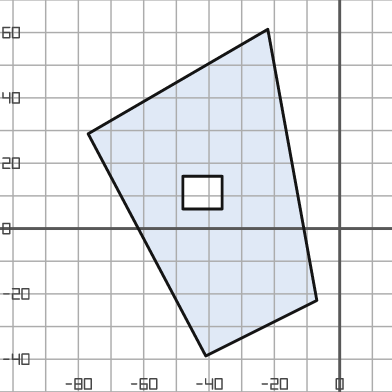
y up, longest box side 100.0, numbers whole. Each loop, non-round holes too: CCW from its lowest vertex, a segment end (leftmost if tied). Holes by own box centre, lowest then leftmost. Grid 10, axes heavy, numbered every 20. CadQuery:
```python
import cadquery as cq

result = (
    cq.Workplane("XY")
    .moveTo(-41.0, -39.0)
    .lineTo(-7.0, -22.0)
    .lineTo(-22.0, 61.0)
    .lineTo(-77.0, 29.0)
    .close()
    .moveTo(-48.0, 6.0)
    .lineTo(-36.0, 6.0)
    .lineTo(-36.0, 16.0)
    .lineTo(-48.0, 16.0)
    .close()
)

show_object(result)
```